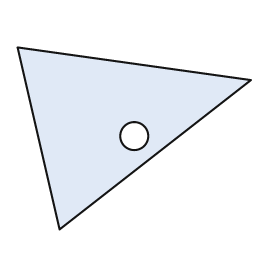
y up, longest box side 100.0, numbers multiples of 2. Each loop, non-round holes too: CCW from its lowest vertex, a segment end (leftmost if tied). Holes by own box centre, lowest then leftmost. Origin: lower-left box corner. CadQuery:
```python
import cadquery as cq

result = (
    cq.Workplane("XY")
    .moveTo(18.0, 0.0)
    .lineTo(100.0, 64.0)
    .lineTo(0.0, 78.0)
    .close()
    .moveTo(50.0, 40.0)
    .circle(6.0)
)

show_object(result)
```